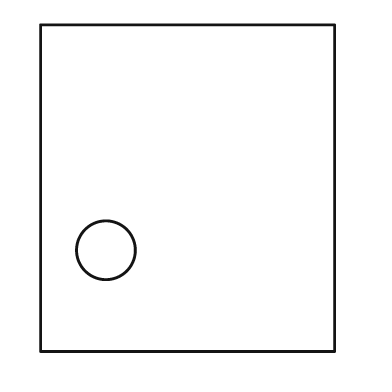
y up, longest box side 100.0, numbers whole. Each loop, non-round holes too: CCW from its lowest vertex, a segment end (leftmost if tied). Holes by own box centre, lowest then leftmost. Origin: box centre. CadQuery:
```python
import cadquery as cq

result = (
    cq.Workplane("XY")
    .moveTo(-45.0, -50.0)
    .lineTo(45.0, -50.0)
    .lineTo(45.0, 50.0)
    .lineTo(-45.0, 50.0)
    .close()
    .moveTo(-25.0, -19.0)
    .circle(9.0)
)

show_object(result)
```